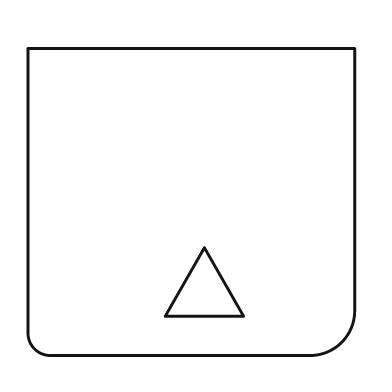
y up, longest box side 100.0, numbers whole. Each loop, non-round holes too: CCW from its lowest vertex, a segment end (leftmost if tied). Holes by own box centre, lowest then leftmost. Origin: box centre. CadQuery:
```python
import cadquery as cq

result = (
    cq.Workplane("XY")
    .moveTo(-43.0, -47.0)
    .lineTo(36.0, -47.0)
    .threePointArc((46.0, -43.0), (50.0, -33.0))
    .lineTo(50.0, 47.0)
    .lineTo(-50.0, 47.0)
    .lineTo(-50.0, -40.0)
    .threePointArc((-48.0, -45.0), (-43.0, -47.0))
    .close()
    .moveTo(-8.0, -35.0)
    .lineTo(16.0, -35.0)
    .lineTo(4.0, -14.0)
    .close()
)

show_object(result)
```